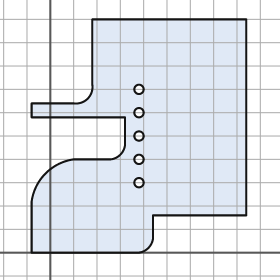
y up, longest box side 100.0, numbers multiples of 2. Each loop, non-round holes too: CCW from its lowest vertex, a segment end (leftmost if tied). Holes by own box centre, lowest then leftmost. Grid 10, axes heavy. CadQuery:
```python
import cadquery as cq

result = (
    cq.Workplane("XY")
    .moveTo(-8.0, 0.0)
    .lineTo(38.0, 0.0)
    .threePointArc((42.0, 2.0), (44.0, 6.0))
    .lineTo(44.0, 16.0)
    .lineTo(84.0, 16.0)
    .lineTo(84.0, 100.0)
    .lineTo(18.0, 100.0)
    .lineTo(18.0, 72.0)
    .threePointArc((16.0, 66.0), (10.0, 64.0))
    .lineTo(-8.0, 64.0)
    .lineTo(-8.0, 58.0)
    .lineTo(32.0, 58.0)
    .lineTo(32.0, 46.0)
    .threePointArc((30.0, 42.0), (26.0, 40.0))
    .lineTo(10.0, 40.0)
    .threePointArc((-2.0, 34.0), (-8.0, 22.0))
    .close()
    .moveTo(38.0, 30.0)
    .circle(2.0)
    .moveTo(38.0, 40.0)
    .circle(2.0)
    .moveTo(38.0, 50.0)
    .circle(2.0)
    .moveTo(38.0, 60.0)
    .circle(2.0)
    .moveTo(38.0, 70.0)
    .circle(2.0)
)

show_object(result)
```